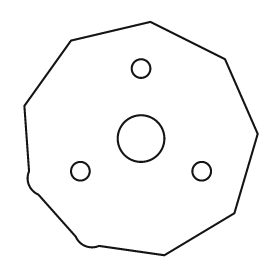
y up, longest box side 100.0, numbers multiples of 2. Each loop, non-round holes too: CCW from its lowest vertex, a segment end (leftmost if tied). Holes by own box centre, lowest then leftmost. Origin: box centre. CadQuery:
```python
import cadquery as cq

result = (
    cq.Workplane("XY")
    .moveTo(10.0, -50.0)
    .lineTo(40.0, -32.0)
    .lineTo(50.0, 2.0)
    .lineTo(36.0, 34.0)
    .lineTo(4.0, 50.0)
    .lineTo(-30.0, 42.0)
    .lineTo(-50.0, 14.0)
    .lineTo(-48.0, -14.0)
    .threePointArc((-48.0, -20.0), (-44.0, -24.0))
    .lineTo(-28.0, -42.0)
    .threePointArc((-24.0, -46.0), (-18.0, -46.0))
    .close()
    .moveTo(-26.0, -14.0)
    .circle(4.0)
    .moveTo(26.0, -14.0)
    .circle(4.0)
    .moveTo(0.0, 0.0)
    .circle(10.0)
    .moveTo(0.0, 30.0)
    .circle(4.0)
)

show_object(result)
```